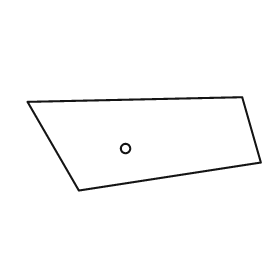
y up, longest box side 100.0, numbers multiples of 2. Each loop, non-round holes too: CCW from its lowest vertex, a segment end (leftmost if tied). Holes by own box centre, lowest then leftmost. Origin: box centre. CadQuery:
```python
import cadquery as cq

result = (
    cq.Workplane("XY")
    .moveTo(-28.0, -20.0)
    .lineTo(50.0, -8.0)
    .lineTo(42.0, 20.0)
    .lineTo(-50.0, 18.0)
    .close()
    .moveTo(-8.0, -2.0)
    .circle(2.0)
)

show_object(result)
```